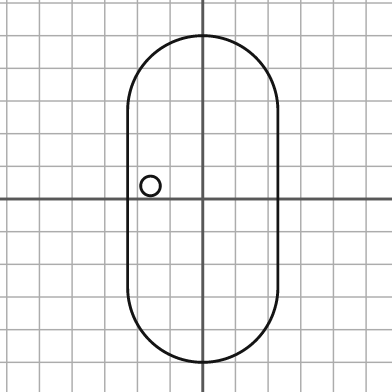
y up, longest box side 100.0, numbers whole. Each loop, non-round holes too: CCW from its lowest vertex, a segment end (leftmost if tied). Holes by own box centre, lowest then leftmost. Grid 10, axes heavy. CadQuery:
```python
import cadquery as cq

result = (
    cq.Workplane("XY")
    .moveTo(-23.0, -27.0)
    .threePointArc((0.0, -50.0), (23.0, -27.0))
    .lineTo(23.0, 27.0)
    .threePointArc((0.0, 50.0), (-23.0, 27.0))
    .close()
    .moveTo(-16.0, 4.0)
    .circle(3.0)
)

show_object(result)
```